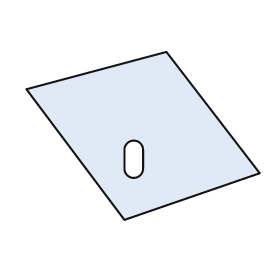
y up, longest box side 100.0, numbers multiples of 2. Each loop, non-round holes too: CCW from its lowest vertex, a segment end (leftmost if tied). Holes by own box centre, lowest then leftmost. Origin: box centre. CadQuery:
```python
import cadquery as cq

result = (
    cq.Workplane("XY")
    .moveTo(-8.0, -36.0)
    .lineTo(50.0, -16.0)
    .lineTo(10.0, 36.0)
    .lineTo(-50.0, 20.0)
    .close()
    .moveTo(-8.0, -14.0)
    .threePointArc((-4.0, -18.0), (0.0, -14.0))
    .lineTo(0.0, -6.0)
    .threePointArc((-4.0, -2.0), (-8.0, -6.0))
    .close()
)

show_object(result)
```